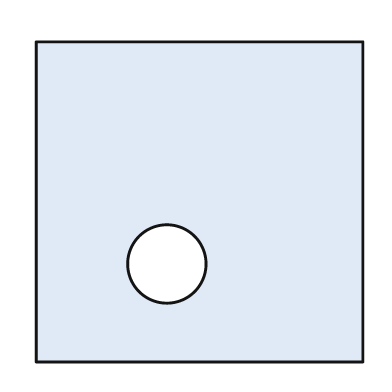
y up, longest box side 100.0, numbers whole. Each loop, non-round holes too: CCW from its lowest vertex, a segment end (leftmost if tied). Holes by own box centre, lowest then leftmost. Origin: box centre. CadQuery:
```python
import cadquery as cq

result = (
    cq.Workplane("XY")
    .moveTo(-50.0, -49.0)
    .lineTo(50.0, -49.0)
    .lineTo(50.0, 49.0)
    .lineTo(-50.0, 49.0)
    .close()
    .moveTo(-10.0, -19.0)
    .circle(12.0)
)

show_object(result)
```